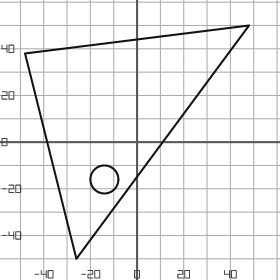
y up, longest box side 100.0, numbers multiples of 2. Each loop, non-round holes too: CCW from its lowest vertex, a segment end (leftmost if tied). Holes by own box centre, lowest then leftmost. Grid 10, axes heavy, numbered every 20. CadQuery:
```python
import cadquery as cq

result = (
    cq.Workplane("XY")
    .moveTo(-26.0, -50.0)
    .lineTo(48.0, 50.0)
    .lineTo(-48.0, 38.0)
    .close()
    .moveTo(-14.0, -16.0)
    .circle(6.0)
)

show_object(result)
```